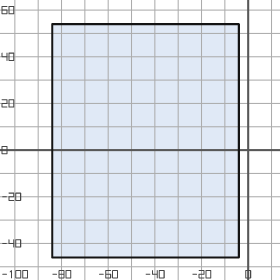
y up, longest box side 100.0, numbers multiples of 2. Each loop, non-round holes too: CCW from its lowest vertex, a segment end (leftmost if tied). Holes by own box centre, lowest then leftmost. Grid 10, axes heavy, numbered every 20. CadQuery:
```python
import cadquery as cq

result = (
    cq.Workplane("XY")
    .moveTo(-84.0, -46.0)
    .lineTo(-4.0, -46.0)
    .lineTo(-4.0, 54.0)
    .lineTo(-84.0, 54.0)
    .close()
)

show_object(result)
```